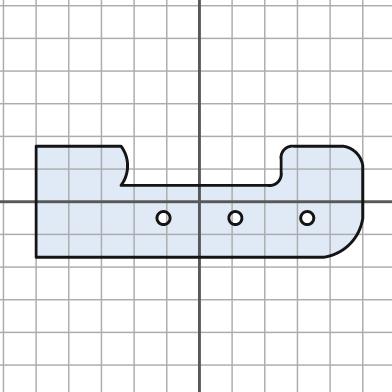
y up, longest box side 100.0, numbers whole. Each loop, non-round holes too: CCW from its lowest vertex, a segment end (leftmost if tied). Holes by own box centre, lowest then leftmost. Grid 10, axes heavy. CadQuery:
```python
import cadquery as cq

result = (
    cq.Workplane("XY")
    .moveTo(-50.0, -17.0)
    .lineTo(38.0, -17.0)
    .threePointArc((46.0, -13.0), (50.0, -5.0))
    .lineTo(50.0, 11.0)
    .threePointArc((48.0, 15.0), (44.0, 17.0))
    .lineTo(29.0, 17.0)
    .threePointArc((26.0, 16.0), (25.0, 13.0))
    .lineTo(25.0, 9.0)
    .threePointArc((24.0, 6.0), (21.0, 5.0))
    .lineTo(-24.0, 5.0)
    .threePointArc((-22.0, 11.0), (-24.0, 17.0))
    .lineTo(-50.0, 17.0)
    .close()
    .moveTo(-11.0, -5.0)
    .circle(2.0)
    .moveTo(11.0, -5.0)
    .circle(2.0)
    .moveTo(33.0, -5.0)
    .circle(2.0)
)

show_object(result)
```